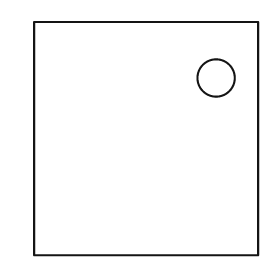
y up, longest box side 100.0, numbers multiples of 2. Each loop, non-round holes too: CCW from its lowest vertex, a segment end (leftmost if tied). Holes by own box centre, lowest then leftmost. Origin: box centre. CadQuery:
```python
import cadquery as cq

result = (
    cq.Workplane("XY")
    .moveTo(-48.0, -50.0)
    .lineTo(48.0, -50.0)
    .lineTo(48.0, 50.0)
    .lineTo(-48.0, 50.0)
    .close()
    .moveTo(30.0, 26.0)
    .circle(8.0)
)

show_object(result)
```